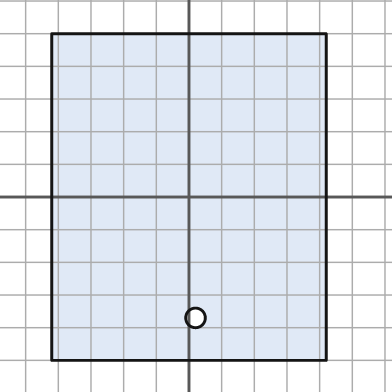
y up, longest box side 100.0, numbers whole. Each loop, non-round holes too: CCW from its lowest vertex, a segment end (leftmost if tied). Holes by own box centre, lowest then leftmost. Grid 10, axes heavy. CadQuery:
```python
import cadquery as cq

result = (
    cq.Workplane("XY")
    .moveTo(-42.0, -50.0)
    .lineTo(42.0, -50.0)
    .lineTo(42.0, 50.0)
    .lineTo(-42.0, 50.0)
    .close()
    .moveTo(2.0, -37.0)
    .circle(3.0)
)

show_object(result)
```